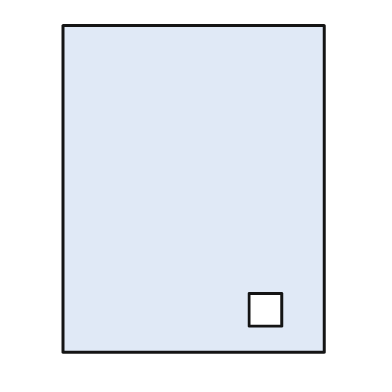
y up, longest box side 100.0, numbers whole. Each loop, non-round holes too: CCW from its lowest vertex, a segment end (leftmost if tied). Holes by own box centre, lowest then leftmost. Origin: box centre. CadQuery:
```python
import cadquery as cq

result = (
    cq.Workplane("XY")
    .moveTo(-40.0, -50.0)
    .lineTo(40.0, -50.0)
    .lineTo(40.0, 50.0)
    .lineTo(-40.0, 50.0)
    .close()
    .moveTo(17.0, -42.0)
    .lineTo(27.0, -42.0)
    .lineTo(27.0, -32.0)
    .lineTo(17.0, -32.0)
    .close()
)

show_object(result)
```